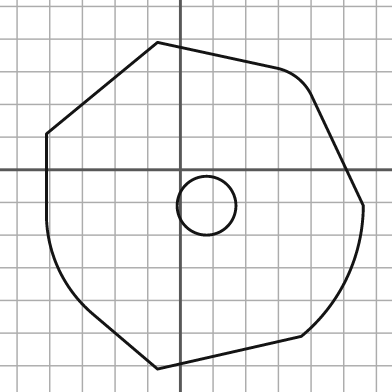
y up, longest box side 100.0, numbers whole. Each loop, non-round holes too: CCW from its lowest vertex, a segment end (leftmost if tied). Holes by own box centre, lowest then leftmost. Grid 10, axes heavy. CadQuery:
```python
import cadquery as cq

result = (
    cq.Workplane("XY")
    .moveTo(-7.0, -61.0)
    .lineTo(37.0, -51.0)
    .threePointArc((51.0, -33.0), (56.0, -11.0))
    .lineTo(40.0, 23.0)
    .threePointArc((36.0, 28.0), (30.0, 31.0))
    .lineTo(-7.0, 39.0)
    .lineTo(-41.0, 11.0)
    .lineTo(-41.0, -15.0)
    .threePointArc((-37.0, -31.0), (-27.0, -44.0))
    .close()
    .moveTo(8.0, -11.0)
    .circle(9.0)
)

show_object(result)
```